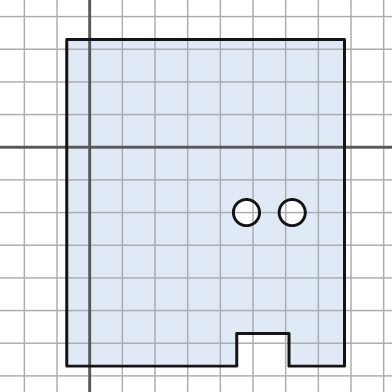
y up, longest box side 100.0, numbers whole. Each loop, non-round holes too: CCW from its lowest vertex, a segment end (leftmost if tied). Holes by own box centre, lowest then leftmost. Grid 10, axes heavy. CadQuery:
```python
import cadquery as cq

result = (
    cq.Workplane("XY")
    .moveTo(-7.0, -67.0)
    .lineTo(45.0, -67.0)
    .lineTo(45.0, -57.0)
    .lineTo(61.0, -57.0)
    .lineTo(61.0, -67.0)
    .lineTo(78.0, -67.0)
    .lineTo(78.0, 33.0)
    .lineTo(-7.0, 33.0)
    .close()
    .moveTo(48.0, -20.0)
    .circle(4.0)
    .moveTo(62.0, -20.0)
    .circle(4.0)
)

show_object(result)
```